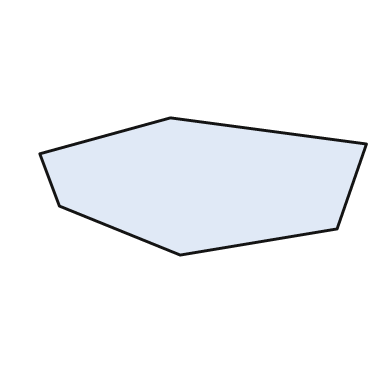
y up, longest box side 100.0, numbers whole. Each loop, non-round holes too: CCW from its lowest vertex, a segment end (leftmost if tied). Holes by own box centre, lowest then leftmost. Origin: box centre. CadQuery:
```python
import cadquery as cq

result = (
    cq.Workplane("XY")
    .moveTo(-7.0, -21.0)
    .lineTo(41.0, -13.0)
    .lineTo(50.0, 13.0)
    .lineTo(-10.0, 21.0)
    .lineTo(-50.0, 10.0)
    .lineTo(-44.0, -6.0)
    .close()
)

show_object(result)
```